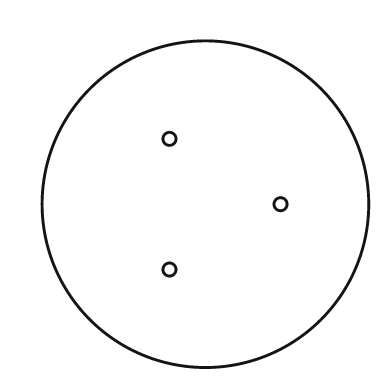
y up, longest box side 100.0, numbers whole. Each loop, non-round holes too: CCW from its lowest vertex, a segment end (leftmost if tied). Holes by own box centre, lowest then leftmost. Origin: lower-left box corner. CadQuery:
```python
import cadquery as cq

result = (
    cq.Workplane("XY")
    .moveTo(50.0, 50.0)
    .circle(50.0)
    .moveTo(39.0, 30.0)
    .circle(2.0)
    .moveTo(73.0, 50.0)
    .circle(2.0)
    .moveTo(39.0, 70.0)
    .circle(2.0)
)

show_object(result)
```